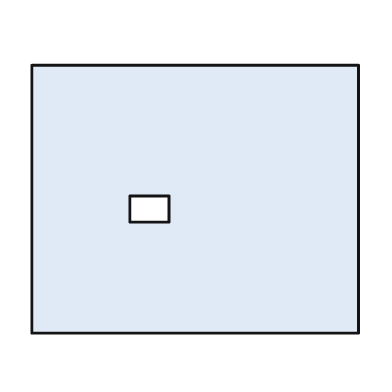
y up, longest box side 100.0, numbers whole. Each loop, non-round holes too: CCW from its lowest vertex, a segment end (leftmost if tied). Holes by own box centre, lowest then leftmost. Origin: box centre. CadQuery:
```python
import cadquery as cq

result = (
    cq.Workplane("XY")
    .moveTo(-50.0, -41.0)
    .lineTo(50.0, -41.0)
    .lineTo(50.0, 41.0)
    .lineTo(-50.0, 41.0)
    .close()
    .moveTo(-20.0, -7.0)
    .lineTo(-8.0, -7.0)
    .lineTo(-8.0, 1.0)
    .lineTo(-20.0, 1.0)
    .close()
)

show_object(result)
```